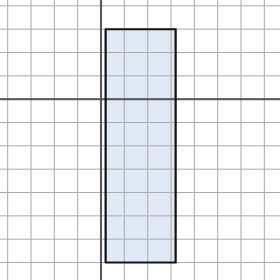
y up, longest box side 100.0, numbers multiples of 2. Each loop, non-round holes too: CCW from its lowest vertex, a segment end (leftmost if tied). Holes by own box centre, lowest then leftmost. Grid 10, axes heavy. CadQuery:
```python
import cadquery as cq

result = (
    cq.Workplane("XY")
    .moveTo(2.0, -70.0)
    .lineTo(32.0, -70.0)
    .lineTo(32.0, 30.0)
    .lineTo(2.0, 30.0)
    .close()
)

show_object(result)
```